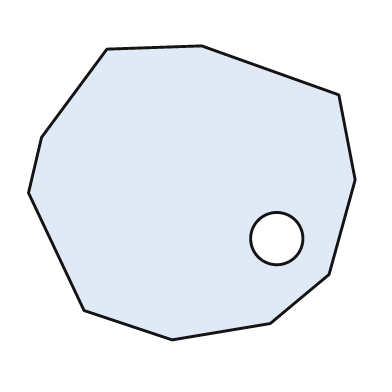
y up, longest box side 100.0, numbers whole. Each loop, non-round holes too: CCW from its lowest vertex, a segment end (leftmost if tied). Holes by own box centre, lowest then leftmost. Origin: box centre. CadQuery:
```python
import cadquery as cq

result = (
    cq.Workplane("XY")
    .moveTo(-6.0, -45.0)
    .lineTo(24.0, -40.0)
    .lineTo(42.0, -25.0)
    .lineTo(50.0, 4.0)
    .lineTo(45.0, 30.0)
    .lineTo(3.0, 45.0)
    .lineTo(-26.0, 44.0)
    .lineTo(-46.0, 17.0)
    .lineTo(-50.0, 0.0)
    .lineTo(-33.0, -36.0)
    .close()
    .moveTo(26.0, -14.0)
    .circle(8.0)
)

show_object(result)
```